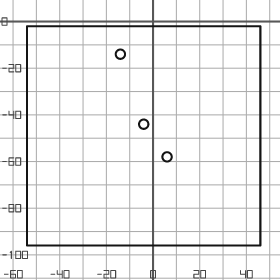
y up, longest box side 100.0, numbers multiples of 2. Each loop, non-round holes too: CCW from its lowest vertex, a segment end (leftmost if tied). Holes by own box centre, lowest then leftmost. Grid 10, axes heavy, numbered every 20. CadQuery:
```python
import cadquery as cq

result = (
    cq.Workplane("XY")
    .moveTo(-54.0, -96.0)
    .lineTo(46.0, -96.0)
    .lineTo(46.0, -2.0)
    .lineTo(-54.0, -2.0)
    .close()
    .moveTo(6.0, -58.0)
    .circle(2.0)
    .moveTo(-4.0, -44.0)
    .circle(2.0)
    .moveTo(-14.0, -14.0)
    .circle(2.0)
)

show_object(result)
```